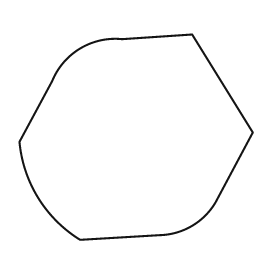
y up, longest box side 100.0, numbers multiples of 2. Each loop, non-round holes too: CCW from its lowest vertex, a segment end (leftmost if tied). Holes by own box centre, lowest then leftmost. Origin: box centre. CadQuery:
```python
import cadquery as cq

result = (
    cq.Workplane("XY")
    .moveTo(-24.0, -44.0)
    .lineTo(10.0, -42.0)
    .threePointArc((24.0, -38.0), (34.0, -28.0))
    .lineTo(50.0, 2.0)
    .lineTo(24.0, 44.0)
    .lineTo(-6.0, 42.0)
    .threePointArc((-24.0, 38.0), (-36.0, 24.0))
    .lineTo(-50.0, -2.0)
    .threePointArc((-42.0, -26.0), (-24.0, -44.0))
    .close()
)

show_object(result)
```